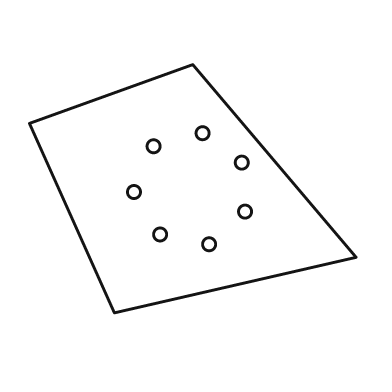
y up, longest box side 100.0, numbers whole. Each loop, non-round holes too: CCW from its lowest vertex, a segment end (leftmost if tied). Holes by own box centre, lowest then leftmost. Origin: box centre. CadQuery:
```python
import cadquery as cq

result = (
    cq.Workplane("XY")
    .moveTo(-24.0, -38.0)
    .lineTo(50.0, -21.0)
    .lineTo(0.0, 38.0)
    .lineTo(-50.0, 20.0)
    .close()
    .moveTo(5.0, -17.0)
    .circle(2.0)
    .moveTo(-10.0, -14.0)
    .circle(2.0)
    .moveTo(16.0, -7.0)
    .circle(2.0)
    .moveTo(-18.0, -1.0)
    .circle(2.0)
    .moveTo(15.0, 8.0)
    .circle(2.0)
    .moveTo(-12.0, 13.0)
    .circle(2.0)
    .moveTo(3.0, 17.0)
    .circle(2.0)
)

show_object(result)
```